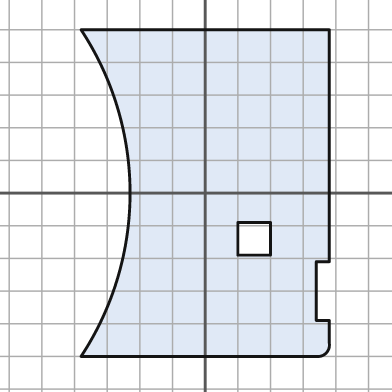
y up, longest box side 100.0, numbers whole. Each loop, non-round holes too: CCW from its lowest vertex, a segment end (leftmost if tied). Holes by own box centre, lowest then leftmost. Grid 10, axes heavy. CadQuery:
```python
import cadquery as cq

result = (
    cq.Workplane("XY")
    .moveTo(-38.0, -50.0)
    .lineTo(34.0, -50.0)
    .threePointArc((37.0, -49.0), (38.0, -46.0))
    .lineTo(38.0, -39.0)
    .lineTo(34.0, -39.0)
    .lineTo(34.0, -21.0)
    .lineTo(38.0, -21.0)
    .lineTo(38.0, 50.0)
    .lineTo(-38.0, 50.0)
    .threePointArc((-23.0, 0.0), (-38.0, -50.0))
    .close()
    .moveTo(10.0, -19.0)
    .lineTo(20.0, -19.0)
    .lineTo(20.0, -9.0)
    .lineTo(10.0, -9.0)
    .close()
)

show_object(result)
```